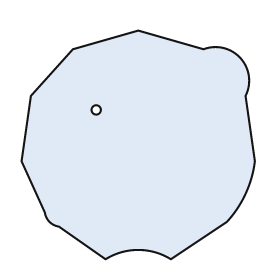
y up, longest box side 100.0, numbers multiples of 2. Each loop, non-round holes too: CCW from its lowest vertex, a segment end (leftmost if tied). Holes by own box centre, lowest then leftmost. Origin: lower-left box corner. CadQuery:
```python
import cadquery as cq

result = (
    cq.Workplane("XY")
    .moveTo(36.0, 0.0)
    .threePointArc((50.0, 4.0), (64.0, 0.0))
    .lineTo(88.0, 16.0)
    .threePointArc((96.0, 28.0), (100.0, 42.0))
    .lineTo(96.0, 70.0)
    .threePointArc((94.0, 86.0), (78.0, 90.0))
    .lineTo(50.0, 98.0)
    .lineTo(22.0, 90.0)
    .lineTo(4.0, 70.0)
    .lineTo(0.0, 42.0)
    .lineTo(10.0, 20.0)
    .threePointArc((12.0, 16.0), (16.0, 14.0))
    .close()
    .moveTo(32.0, 64.0)
    .circle(2.0)
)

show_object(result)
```